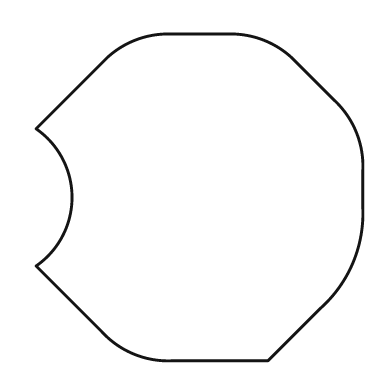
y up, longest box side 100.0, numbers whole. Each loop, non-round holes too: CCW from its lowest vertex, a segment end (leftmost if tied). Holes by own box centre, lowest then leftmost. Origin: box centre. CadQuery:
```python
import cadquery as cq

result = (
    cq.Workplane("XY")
    .moveTo(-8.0, -50.0)
    .lineTo(21.0, -50.0)
    .lineTo(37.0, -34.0)
    .threePointArc((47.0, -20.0), (50.0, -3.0))
    .lineTo(50.0, 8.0)
    .threePointArc((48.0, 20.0), (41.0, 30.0))
    .lineTo(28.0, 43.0)
    .threePointArc((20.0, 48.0), (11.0, 50.0))
    .lineTo(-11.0, 50.0)
    .threePointArc((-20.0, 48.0), (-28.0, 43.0))
    .lineTo(-50.0, 21.0)
    .threePointArc((-39.0, 0.0), (-50.0, -21.0))
    .lineTo(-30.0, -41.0)
    .threePointArc((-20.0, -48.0), (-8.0, -50.0))
    .close()
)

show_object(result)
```